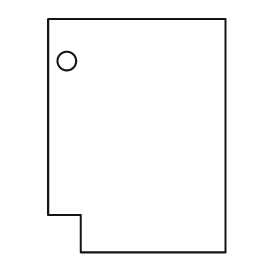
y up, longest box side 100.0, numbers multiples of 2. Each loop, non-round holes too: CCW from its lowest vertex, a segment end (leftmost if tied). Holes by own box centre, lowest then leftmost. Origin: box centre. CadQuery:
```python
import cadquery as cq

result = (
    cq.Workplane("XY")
    .moveTo(-24.0, -50.0)
    .lineTo(38.0, -50.0)
    .lineTo(38.0, 50.0)
    .lineTo(-38.0, 50.0)
    .lineTo(-38.0, -34.0)
    .lineTo(-24.0, -34.0)
    .close()
    .moveTo(-30.0, 32.0)
    .circle(4.0)
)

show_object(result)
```